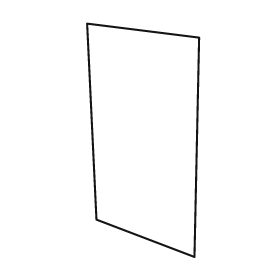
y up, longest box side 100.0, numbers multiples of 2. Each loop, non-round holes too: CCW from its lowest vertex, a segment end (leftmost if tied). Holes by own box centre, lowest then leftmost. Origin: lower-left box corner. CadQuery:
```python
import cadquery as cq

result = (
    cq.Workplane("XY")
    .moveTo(46.0, 0.0)
    .lineTo(48.0, 94.0)
    .lineTo(0.0, 100.0)
    .lineTo(4.0, 16.0)
    .close()
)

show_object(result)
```